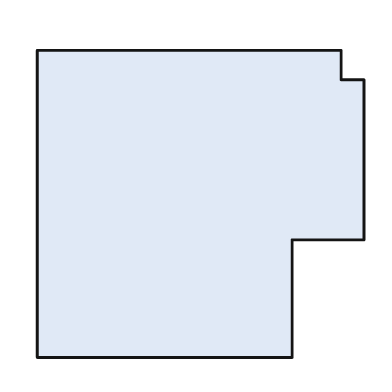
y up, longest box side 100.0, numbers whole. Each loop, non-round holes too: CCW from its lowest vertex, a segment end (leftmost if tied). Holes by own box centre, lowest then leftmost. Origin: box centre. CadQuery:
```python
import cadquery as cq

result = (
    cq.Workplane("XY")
    .moveTo(-50.0, -47.0)
    .lineTo(28.0, -47.0)
    .lineTo(28.0, -11.0)
    .lineTo(50.0, -11.0)
    .lineTo(50.0, 38.0)
    .lineTo(43.0, 38.0)
    .lineTo(43.0, 47.0)
    .lineTo(-50.0, 47.0)
    .close()
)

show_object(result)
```